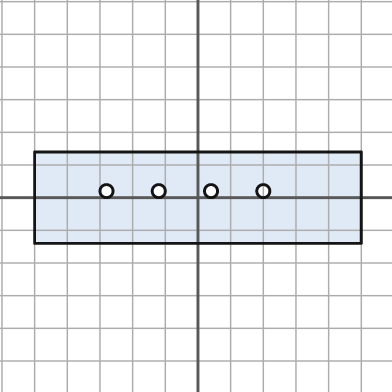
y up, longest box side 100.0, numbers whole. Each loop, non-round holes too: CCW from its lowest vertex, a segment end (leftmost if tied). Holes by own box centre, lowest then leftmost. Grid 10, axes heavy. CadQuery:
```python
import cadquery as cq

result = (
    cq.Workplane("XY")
    .moveTo(-50.0, -14.0)
    .lineTo(50.0, -14.0)
    .lineTo(50.0, 14.0)
    .lineTo(-50.0, 14.0)
    .close()
    .moveTo(-28.0, 2.0)
    .circle(2.0)
    .moveTo(-12.0, 2.0)
    .circle(2.0)
    .moveTo(4.0, 2.0)
    .circle(2.0)
    .moveTo(20.0, 2.0)
    .circle(2.0)
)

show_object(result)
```